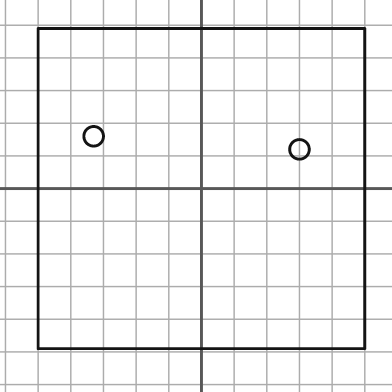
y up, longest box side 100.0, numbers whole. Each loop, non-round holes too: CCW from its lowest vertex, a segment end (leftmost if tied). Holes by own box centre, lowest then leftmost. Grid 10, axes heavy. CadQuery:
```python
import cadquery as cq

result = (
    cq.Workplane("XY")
    .moveTo(-50.0, -49.0)
    .lineTo(50.0, -49.0)
    .lineTo(50.0, 49.0)
    .lineTo(-50.0, 49.0)
    .close()
    .moveTo(30.0, 12.0)
    .circle(3.0)
    .moveTo(-33.0, 16.0)
    .circle(3.0)
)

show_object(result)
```